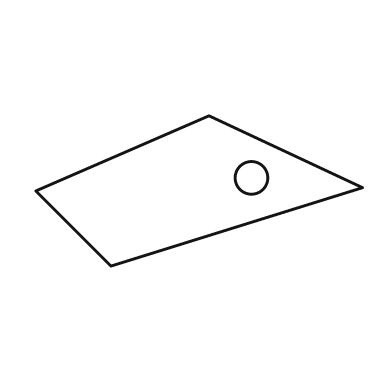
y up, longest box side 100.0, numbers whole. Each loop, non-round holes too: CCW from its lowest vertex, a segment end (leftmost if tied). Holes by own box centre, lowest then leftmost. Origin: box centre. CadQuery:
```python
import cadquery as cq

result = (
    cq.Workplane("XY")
    .moveTo(-27.0, -23.0)
    .lineTo(50.0, 1.0)
    .lineTo(3.0, 23.0)
    .lineTo(-50.0, 0.0)
    .close()
    .moveTo(16.0, 4.0)
    .circle(5.0)
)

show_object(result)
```